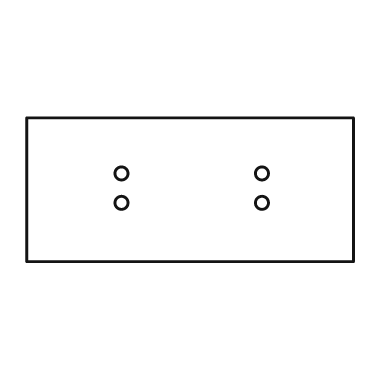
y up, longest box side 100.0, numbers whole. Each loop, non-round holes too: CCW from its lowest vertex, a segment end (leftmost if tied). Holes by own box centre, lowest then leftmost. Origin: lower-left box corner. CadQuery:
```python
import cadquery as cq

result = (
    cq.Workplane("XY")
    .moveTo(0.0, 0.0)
    .lineTo(100.0, 0.0)
    .lineTo(100.0, 44.0)
    .lineTo(0.0, 44.0)
    .close()
    .moveTo(29.0, 18.0)
    .circle(2.0)
    .moveTo(72.0, 18.0)
    .circle(2.0)
    .moveTo(29.0, 27.0)
    .circle(2.0)
    .moveTo(72.0, 27.0)
    .circle(2.0)
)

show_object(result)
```